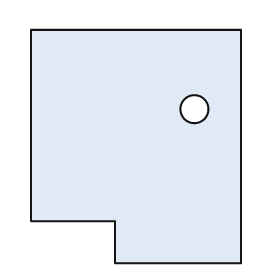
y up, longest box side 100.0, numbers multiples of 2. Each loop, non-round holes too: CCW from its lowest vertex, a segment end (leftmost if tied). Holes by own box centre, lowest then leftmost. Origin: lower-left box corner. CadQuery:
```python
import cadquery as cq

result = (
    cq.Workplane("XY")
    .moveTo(36.0, 0.0)
    .lineTo(90.0, 0.0)
    .lineTo(90.0, 100.0)
    .lineTo(0.0, 100.0)
    .lineTo(0.0, 18.0)
    .lineTo(36.0, 18.0)
    .close()
    .moveTo(70.0, 66.0)
    .circle(6.0)
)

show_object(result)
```